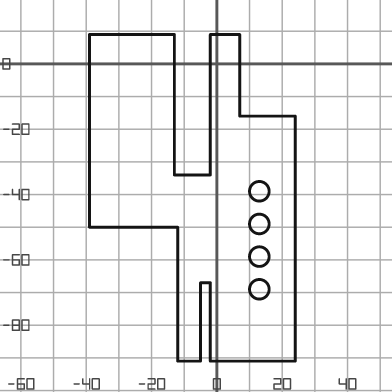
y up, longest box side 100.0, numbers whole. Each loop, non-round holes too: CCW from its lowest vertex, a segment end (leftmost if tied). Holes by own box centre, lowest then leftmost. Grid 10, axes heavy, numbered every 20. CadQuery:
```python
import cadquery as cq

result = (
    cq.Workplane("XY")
    .moveTo(-12.0, -91.0)
    .lineTo(-5.0, -91.0)
    .lineTo(-5.0, -67.0)
    .lineTo(-2.0, -67.0)
    .lineTo(-2.0, -91.0)
    .lineTo(24.0, -91.0)
    .lineTo(24.0, -16.0)
    .lineTo(7.0, -16.0)
    .lineTo(7.0, 9.0)
    .lineTo(-2.0, 9.0)
    .lineTo(-2.0, -34.0)
    .lineTo(-13.0, -34.0)
    .lineTo(-13.0, 9.0)
    .lineTo(-39.0, 9.0)
    .lineTo(-39.0, -50.0)
    .lineTo(-12.0, -50.0)
    .close()
    .moveTo(13.0, -69.0)
    .circle(3.0)
    .moveTo(13.0, -59.0)
    .circle(3.0)
    .moveTo(13.0, -49.0)
    .circle(3.0)
    .moveTo(13.0, -39.0)
    .circle(3.0)
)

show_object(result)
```